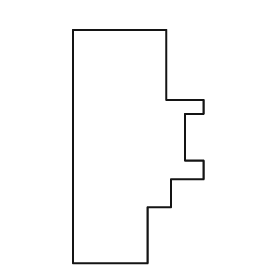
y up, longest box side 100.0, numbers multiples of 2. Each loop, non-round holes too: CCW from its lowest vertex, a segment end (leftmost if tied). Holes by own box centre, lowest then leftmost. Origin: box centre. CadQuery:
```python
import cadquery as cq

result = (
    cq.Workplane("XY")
    .moveTo(-28.0, -50.0)
    .lineTo(4.0, -50.0)
    .lineTo(4.0, -26.0)
    .lineTo(14.0, -26.0)
    .lineTo(14.0, -14.0)
    .lineTo(28.0, -14.0)
    .lineTo(28.0, -6.0)
    .lineTo(20.0, -6.0)
    .lineTo(20.0, 14.0)
    .lineTo(28.0, 14.0)
    .lineTo(28.0, 20.0)
    .lineTo(12.0, 20.0)
    .lineTo(12.0, 50.0)
    .lineTo(-28.0, 50.0)
    .close()
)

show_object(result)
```